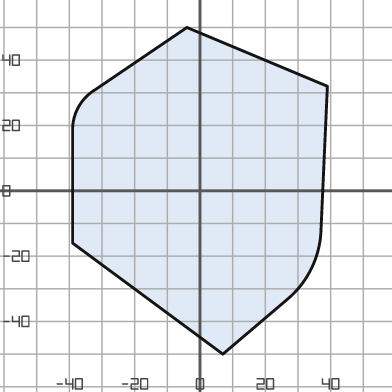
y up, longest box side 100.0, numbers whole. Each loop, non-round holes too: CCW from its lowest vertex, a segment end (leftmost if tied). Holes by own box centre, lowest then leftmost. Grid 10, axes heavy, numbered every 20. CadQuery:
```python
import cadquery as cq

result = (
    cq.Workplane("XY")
    .moveTo(7.0, -50.0)
    .lineTo(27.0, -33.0)
    .threePointArc((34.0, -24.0), (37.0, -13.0))
    .lineTo(39.0, 32.0)
    .lineTo(-4.0, 50.0)
    .lineTo(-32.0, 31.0)
    .threePointArc((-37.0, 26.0), (-39.0, 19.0))
    .lineTo(-39.0, -16.0)
    .close()
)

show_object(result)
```